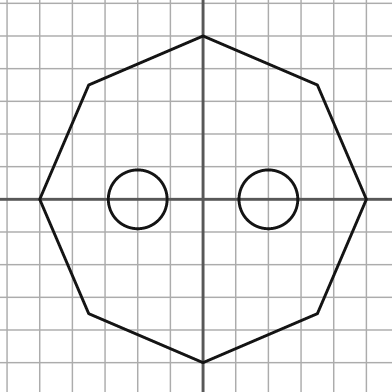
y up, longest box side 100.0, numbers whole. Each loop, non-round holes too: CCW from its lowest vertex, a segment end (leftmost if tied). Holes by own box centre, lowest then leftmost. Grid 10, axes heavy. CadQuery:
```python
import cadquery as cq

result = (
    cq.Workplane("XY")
    .moveTo(0.0, -50.0)
    .lineTo(35.0, -35.0)
    .lineTo(50.0, 0.0)
    .lineTo(35.0, 35.0)
    .lineTo(0.0, 50.0)
    .lineTo(-35.0, 35.0)
    .lineTo(-50.0, 0.0)
    .lineTo(-35.0, -35.0)
    .close()
    .moveTo(-20.0, 0.0)
    .circle(9.0)
    .moveTo(20.0, 0.0)
    .circle(9.0)
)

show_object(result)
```